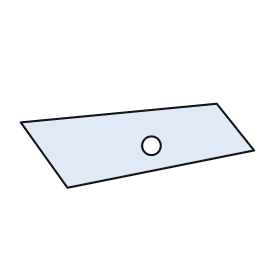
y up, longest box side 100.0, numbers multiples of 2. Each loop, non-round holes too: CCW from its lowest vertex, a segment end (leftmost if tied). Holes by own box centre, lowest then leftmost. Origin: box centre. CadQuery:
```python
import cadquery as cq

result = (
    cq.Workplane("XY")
    .moveTo(-30.0, -18.0)
    .lineTo(50.0, -2.0)
    .lineTo(34.0, 18.0)
    .lineTo(-50.0, 10.0)
    .close()
    .moveTo(6.0, 0.0)
    .circle(4.0)
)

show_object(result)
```